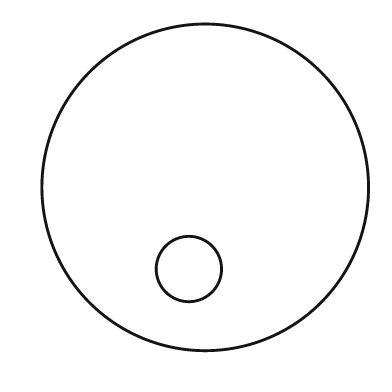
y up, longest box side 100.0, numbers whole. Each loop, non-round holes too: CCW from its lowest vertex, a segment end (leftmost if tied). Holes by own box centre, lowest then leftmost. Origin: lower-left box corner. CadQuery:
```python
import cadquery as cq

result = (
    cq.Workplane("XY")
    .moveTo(50.0, 50.0)
    .circle(50.0)
    .moveTo(45.0, 25.0)
    .circle(10.0)
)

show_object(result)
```